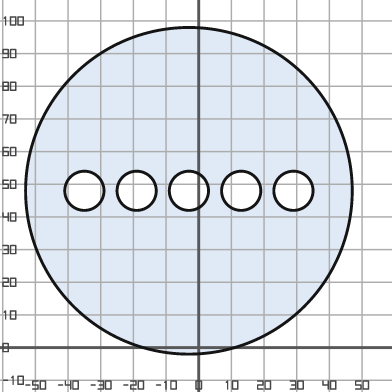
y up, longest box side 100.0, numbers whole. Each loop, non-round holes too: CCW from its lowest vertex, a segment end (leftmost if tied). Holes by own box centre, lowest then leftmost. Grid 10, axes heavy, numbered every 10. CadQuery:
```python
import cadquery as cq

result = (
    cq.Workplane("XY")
    .moveTo(-3.0, 48.0)
    .circle(50.0)
    .moveTo(-35.0, 48.0)
    .circle(6.0)
    .moveTo(-19.0, 48.0)
    .circle(6.0)
    .moveTo(-3.0, 48.0)
    .circle(6.0)
    .moveTo(13.0, 48.0)
    .circle(6.0)
    .moveTo(29.0, 48.0)
    .circle(6.0)
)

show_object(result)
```